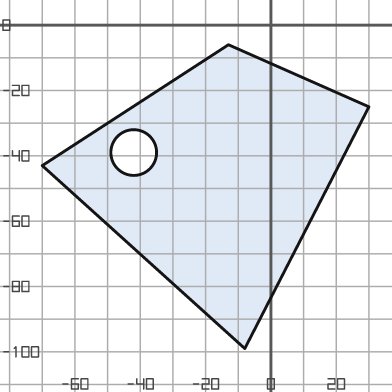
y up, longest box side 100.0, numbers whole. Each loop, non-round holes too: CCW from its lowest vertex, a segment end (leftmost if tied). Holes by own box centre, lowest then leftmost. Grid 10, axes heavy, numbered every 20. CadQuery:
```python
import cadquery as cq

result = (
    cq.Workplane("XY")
    .moveTo(-8.0, -99.0)
    .lineTo(30.0, -25.0)
    .lineTo(-13.0, -6.0)
    .lineTo(-70.0, -43.0)
    .close()
    .moveTo(-42.0, -39.0)
    .circle(7.0)
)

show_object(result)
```